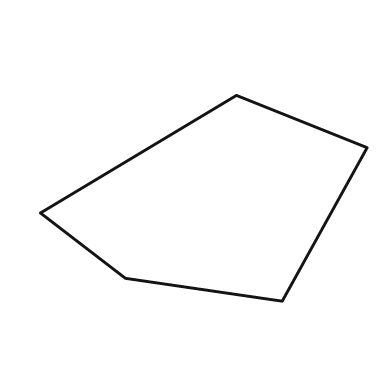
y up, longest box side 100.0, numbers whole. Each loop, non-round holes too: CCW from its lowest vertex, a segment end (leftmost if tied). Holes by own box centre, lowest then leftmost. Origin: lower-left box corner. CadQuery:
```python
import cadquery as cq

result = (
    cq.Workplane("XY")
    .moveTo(74.0, 0.0)
    .lineTo(100.0, 47.0)
    .lineTo(60.0, 63.0)
    .lineTo(0.0, 27.0)
    .lineTo(26.0, 7.0)
    .close()
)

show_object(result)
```